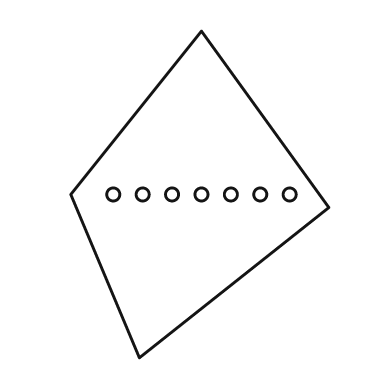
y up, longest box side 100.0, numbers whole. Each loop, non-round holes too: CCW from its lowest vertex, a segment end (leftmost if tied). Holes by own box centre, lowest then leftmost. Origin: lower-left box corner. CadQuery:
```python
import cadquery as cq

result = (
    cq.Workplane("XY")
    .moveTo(21.0, 0.0)
    .lineTo(79.0, 46.0)
    .lineTo(40.0, 100.0)
    .lineTo(0.0, 50.0)
    .close()
    .moveTo(13.0, 50.0)
    .circle(2.0)
    .moveTo(22.0, 50.0)
    .circle(2.0)
    .moveTo(31.0, 50.0)
    .circle(2.0)
    .moveTo(40.0, 50.0)
    .circle(2.0)
    .moveTo(49.0, 50.0)
    .circle(2.0)
    .moveTo(58.0, 50.0)
    .circle(2.0)
    .moveTo(67.0, 50.0)
    .circle(2.0)
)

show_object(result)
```